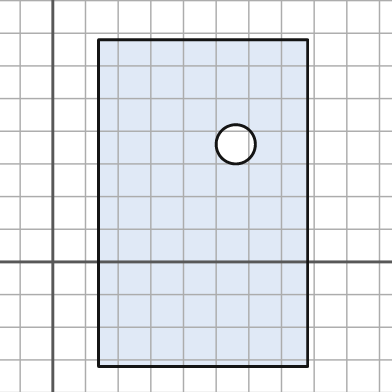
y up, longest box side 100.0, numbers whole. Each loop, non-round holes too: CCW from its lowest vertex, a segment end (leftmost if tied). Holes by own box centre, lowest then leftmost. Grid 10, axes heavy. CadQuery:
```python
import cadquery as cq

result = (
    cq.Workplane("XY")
    .moveTo(14.0, -32.0)
    .lineTo(78.0, -32.0)
    .lineTo(78.0, 68.0)
    .lineTo(14.0, 68.0)
    .close()
    .moveTo(56.0, 36.0)
    .circle(6.0)
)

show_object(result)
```